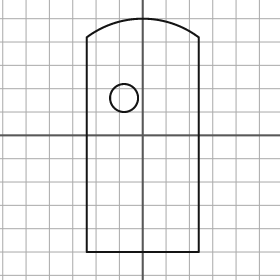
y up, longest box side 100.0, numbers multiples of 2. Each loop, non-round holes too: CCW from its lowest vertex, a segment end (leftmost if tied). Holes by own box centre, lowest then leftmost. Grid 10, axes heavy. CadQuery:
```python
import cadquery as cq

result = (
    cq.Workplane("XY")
    .moveTo(-24.0, -50.0)
    .lineTo(24.0, -50.0)
    .lineTo(24.0, 42.0)
    .threePointArc((0.0, 50.0), (-24.0, 42.0))
    .close()
    .moveTo(-8.0, 16.0)
    .circle(6.0)
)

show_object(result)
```